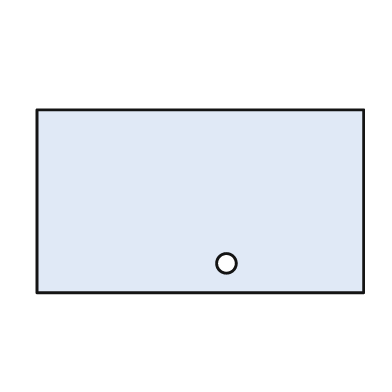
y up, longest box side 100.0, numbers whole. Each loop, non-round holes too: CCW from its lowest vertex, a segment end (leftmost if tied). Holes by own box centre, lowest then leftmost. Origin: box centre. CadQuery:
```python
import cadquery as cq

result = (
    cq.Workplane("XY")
    .moveTo(-50.0, -28.0)
    .lineTo(50.0, -28.0)
    .lineTo(50.0, 28.0)
    .lineTo(-50.0, 28.0)
    .close()
    .moveTo(8.0, -19.0)
    .circle(3.0)
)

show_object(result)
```